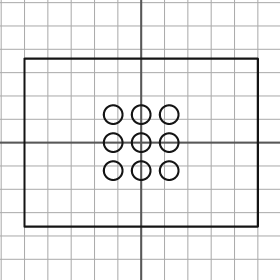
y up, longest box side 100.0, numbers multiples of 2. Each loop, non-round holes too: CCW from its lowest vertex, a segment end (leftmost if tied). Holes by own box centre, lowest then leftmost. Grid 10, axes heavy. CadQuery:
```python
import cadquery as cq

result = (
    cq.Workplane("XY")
    .moveTo(-50.0, -36.0)
    .lineTo(50.0, -36.0)
    .lineTo(50.0, 36.0)
    .lineTo(-50.0, 36.0)
    .close()
    .moveTo(-12.0, -12.0)
    .circle(4.0)
    .moveTo(0.0, -12.0)
    .circle(4.0)
    .moveTo(12.0, -12.0)
    .circle(4.0)
    .moveTo(-12.0, 0.0)
    .circle(4.0)
    .moveTo(0.0, 0.0)
    .circle(4.0)
    .moveTo(12.0, 0.0)
    .circle(4.0)
    .moveTo(-12.0, 12.0)
    .circle(4.0)
    .moveTo(0.0, 12.0)
    .circle(4.0)
    .moveTo(12.0, 12.0)
    .circle(4.0)
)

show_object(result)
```